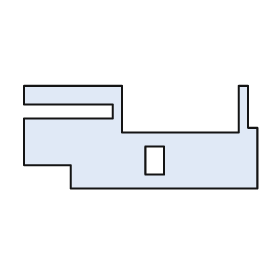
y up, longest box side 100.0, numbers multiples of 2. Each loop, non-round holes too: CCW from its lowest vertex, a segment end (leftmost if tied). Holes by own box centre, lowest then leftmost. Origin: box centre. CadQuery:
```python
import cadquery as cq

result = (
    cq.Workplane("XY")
    .moveTo(-30.0, -22.0)
    .lineTo(50.0, -22.0)
    .lineTo(50.0, 4.0)
    .lineTo(46.0, 4.0)
    .lineTo(46.0, 22.0)
    .lineTo(42.0, 22.0)
    .lineTo(42.0, 2.0)
    .lineTo(-8.0, 2.0)
    .lineTo(-8.0, 22.0)
    .lineTo(-50.0, 22.0)
    .lineTo(-50.0, 14.0)
    .lineTo(-12.0, 14.0)
    .lineTo(-12.0, 8.0)
    .lineTo(-50.0, 8.0)
    .lineTo(-50.0, -12.0)
    .lineTo(-30.0, -12.0)
    .close()
    .moveTo(2.0, -16.0)
    .lineTo(10.0, -16.0)
    .lineTo(10.0, -4.0)
    .lineTo(2.0, -4.0)
    .close()
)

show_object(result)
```